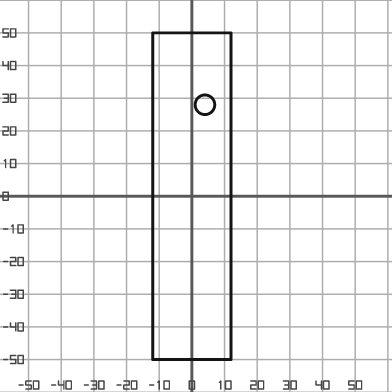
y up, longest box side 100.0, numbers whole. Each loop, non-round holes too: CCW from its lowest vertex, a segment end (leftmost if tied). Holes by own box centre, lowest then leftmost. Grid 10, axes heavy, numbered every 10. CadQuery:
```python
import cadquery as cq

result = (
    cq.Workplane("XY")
    .moveTo(-12.0, -50.0)
    .lineTo(12.0, -50.0)
    .lineTo(12.0, 50.0)
    .lineTo(-12.0, 50.0)
    .close()
    .moveTo(4.0, 28.0)
    .circle(3.0)
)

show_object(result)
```